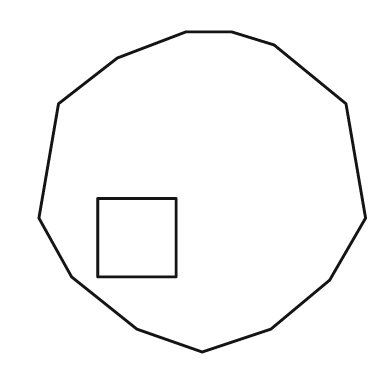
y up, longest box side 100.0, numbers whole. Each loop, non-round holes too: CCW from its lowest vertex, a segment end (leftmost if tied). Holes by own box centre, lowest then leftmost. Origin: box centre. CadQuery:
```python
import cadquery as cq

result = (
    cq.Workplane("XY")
    .moveTo(0.0, -49.0)
    .lineTo(21.0, -42.0)
    .lineTo(39.0, -27.0)
    .lineTo(50.0, -8.0)
    .lineTo(44.0, 27.0)
    .lineTo(22.0, 45.0)
    .lineTo(9.0, 49.0)
    .lineTo(-5.0, 49.0)
    .lineTo(-26.0, 41.0)
    .lineTo(-44.0, 27.0)
    .lineTo(-50.0, -8.0)
    .lineTo(-40.0, -26.0)
    .lineTo(-20.0, -42.0)
    .close()
    .moveTo(-32.0, -26.0)
    .lineTo(-8.0, -26.0)
    .lineTo(-8.0, -2.0)
    .lineTo(-32.0, -2.0)
    .close()
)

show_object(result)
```